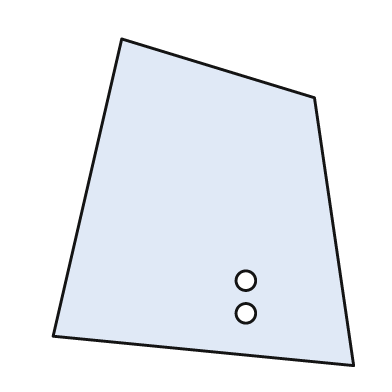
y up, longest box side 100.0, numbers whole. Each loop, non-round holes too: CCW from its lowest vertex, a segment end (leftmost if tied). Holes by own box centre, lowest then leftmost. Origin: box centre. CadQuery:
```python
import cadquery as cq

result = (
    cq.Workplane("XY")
    .moveTo(46.0, -50.0)
    .lineTo(34.0, 32.0)
    .lineTo(-25.0, 50.0)
    .lineTo(-46.0, -41.0)
    .close()
    .moveTo(13.0, -34.0)
    .circle(3.0)
    .moveTo(13.0, -24.0)
    .circle(3.0)
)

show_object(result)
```